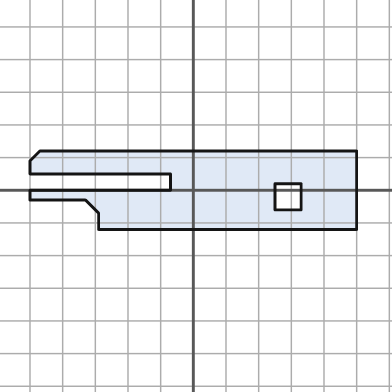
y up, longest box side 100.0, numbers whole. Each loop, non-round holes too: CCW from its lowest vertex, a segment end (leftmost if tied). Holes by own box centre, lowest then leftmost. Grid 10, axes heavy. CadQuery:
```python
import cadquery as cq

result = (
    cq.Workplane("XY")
    .moveTo(-29.0, -12.0)
    .lineTo(50.0, -12.0)
    .lineTo(50.0, 12.0)
    .lineTo(-47.0, 12.0)
    .lineTo(-50.0, 9.0)
    .lineTo(-50.0, 5.0)
    .lineTo(-7.0, 5.0)
    .lineTo(-7.0, 0.0)
    .lineTo(-50.0, 0.0)
    .lineTo(-50.0, -3.0)
    .lineTo(-33.0, -3.0)
    .lineTo(-29.0, -7.0)
    .close()
    .moveTo(25.0, -6.0)
    .lineTo(33.0, -6.0)
    .lineTo(33.0, 2.0)
    .lineTo(25.0, 2.0)
    .close()
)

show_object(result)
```